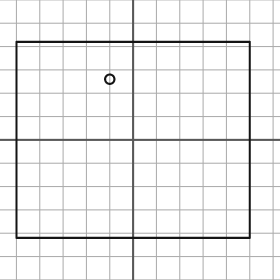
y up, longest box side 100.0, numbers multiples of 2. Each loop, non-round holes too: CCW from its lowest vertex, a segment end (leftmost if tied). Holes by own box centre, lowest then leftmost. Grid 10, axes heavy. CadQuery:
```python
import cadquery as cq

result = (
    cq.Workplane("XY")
    .moveTo(-50.0, -42.0)
    .lineTo(50.0, -42.0)
    .lineTo(50.0, 42.0)
    .lineTo(-50.0, 42.0)
    .close()
    .moveTo(-10.0, 26.0)
    .circle(2.0)
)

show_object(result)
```